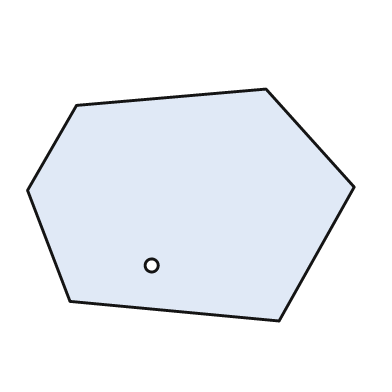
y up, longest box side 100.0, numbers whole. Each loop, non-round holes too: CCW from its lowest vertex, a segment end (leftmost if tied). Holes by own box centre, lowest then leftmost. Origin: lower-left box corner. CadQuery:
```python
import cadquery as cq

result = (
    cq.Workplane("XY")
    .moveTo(77.0, 0.0)
    .lineTo(100.0, 41.0)
    .lineTo(73.0, 71.0)
    .lineTo(15.0, 66.0)
    .lineTo(0.0, 40.0)
    .lineTo(13.0, 6.0)
    .close()
    .moveTo(38.0, 17.0)
    .circle(2.0)
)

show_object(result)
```